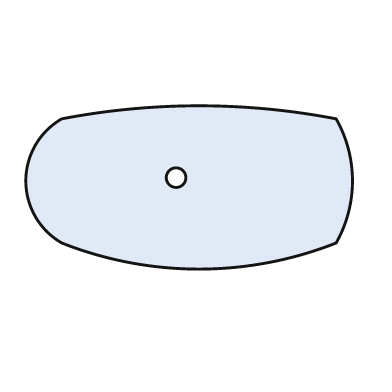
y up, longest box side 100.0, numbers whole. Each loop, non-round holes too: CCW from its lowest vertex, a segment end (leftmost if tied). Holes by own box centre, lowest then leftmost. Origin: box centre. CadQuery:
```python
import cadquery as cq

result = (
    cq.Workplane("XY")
    .moveTo(-39.0, -17.0)
    .threePointArc((3.0, -25.0), (45.0, -17.0))
    .threePointArc((50.0, 2.0), (45.0, 21.0))
    .threePointArc((3.0, 25.0), (-39.0, 21.0))
    .threePointArc((-50.0, 2.0), (-39.0, -17.0))
    .close()
    .moveTo(-4.0, 3.0)
    .circle(3.0)
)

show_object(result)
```